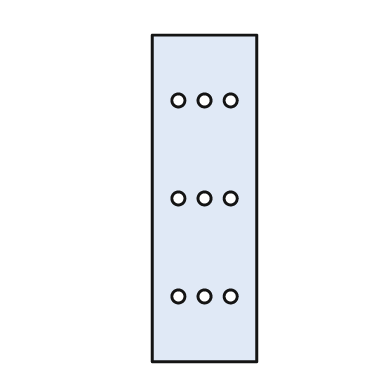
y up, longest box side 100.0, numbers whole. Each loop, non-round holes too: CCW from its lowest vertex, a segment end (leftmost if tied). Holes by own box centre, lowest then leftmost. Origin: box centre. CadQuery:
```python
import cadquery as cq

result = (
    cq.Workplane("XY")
    .moveTo(-16.0, -50.0)
    .lineTo(16.0, -50.0)
    .lineTo(16.0, 50.0)
    .lineTo(-16.0, 50.0)
    .close()
    .moveTo(-8.0, -30.0)
    .circle(2.0)
    .moveTo(0.0, -30.0)
    .circle(2.0)
    .moveTo(8.0, -30.0)
    .circle(2.0)
    .moveTo(-8.0, 0.0)
    .circle(2.0)
    .moveTo(0.0, 0.0)
    .circle(2.0)
    .moveTo(8.0, 0.0)
    .circle(2.0)
    .moveTo(-8.0, 30.0)
    .circle(2.0)
    .moveTo(0.0, 30.0)
    .circle(2.0)
    .moveTo(8.0, 30.0)
    .circle(2.0)
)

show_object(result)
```